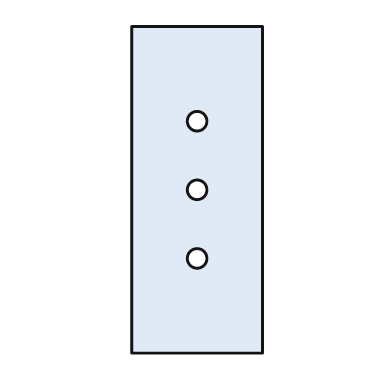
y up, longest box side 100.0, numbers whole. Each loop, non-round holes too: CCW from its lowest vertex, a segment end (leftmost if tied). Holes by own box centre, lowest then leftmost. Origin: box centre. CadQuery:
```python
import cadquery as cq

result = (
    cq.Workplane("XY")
    .moveTo(-20.0, -50.0)
    .lineTo(20.0, -50.0)
    .lineTo(20.0, 50.0)
    .lineTo(-20.0, 50.0)
    .close()
    .moveTo(0.0, -21.0)
    .circle(3.0)
    .moveTo(0.0, 0.0)
    .circle(3.0)
    .moveTo(0.0, 21.0)
    .circle(3.0)
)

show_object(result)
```